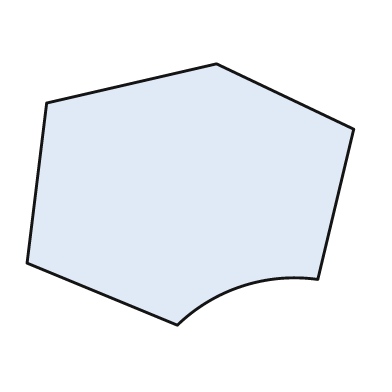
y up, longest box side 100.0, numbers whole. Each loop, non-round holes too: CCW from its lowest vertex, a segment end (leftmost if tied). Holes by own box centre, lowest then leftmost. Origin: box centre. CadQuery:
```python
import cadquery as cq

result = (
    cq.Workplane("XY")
    .moveTo(-4.0, -40.0)
    .threePointArc((16.0, -28.0), (39.0, -26.0))
    .lineTo(50.0, 20.0)
    .lineTo(8.0, 40.0)
    .lineTo(-44.0, 28.0)
    .lineTo(-50.0, -21.0)
    .close()
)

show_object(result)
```